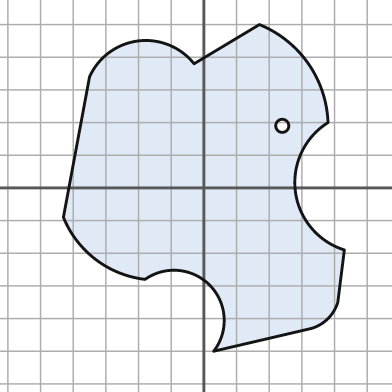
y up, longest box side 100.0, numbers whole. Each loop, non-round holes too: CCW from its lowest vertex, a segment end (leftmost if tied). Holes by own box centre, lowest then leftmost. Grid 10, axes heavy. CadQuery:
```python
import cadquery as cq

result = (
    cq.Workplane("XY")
    .moveTo(3.0, -50.0)
    .lineTo(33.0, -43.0)
    .threePointArc((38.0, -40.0), (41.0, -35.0))
    .lineTo(43.0, -19.0)
    .threePointArc((28.0, -1.0), (38.0, 20.0))
    .threePointArc((32.0, 38.0), (17.0, 50.0))
    .lineTo(-3.0, 38.0)
    .threePointArc((-20.0, 45.0), (-35.0, 34.0))
    .lineTo(-43.0, -9.0)
    .threePointArc((-33.0, -22.0), (-18.0, -28.0))
    .threePointArc((2.0, -30.0), (3.0, -50.0))
    .close()
    .moveTo(24.0, 19.0)
    .circle(2.0)
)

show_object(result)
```